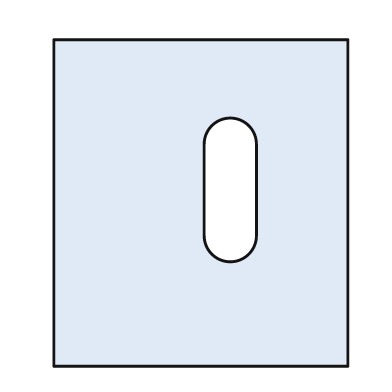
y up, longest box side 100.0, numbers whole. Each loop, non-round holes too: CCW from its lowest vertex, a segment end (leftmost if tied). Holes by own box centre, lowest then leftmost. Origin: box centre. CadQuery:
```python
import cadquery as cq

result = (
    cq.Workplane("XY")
    .moveTo(-45.0, -50.0)
    .lineTo(45.0, -50.0)
    .lineTo(45.0, 50.0)
    .lineTo(-45.0, 50.0)
    .close()
    .moveTo(1.0, -10.0)
    .threePointArc((9.0, -18.0), (17.0, -10.0))
    .lineTo(17.0, 18.0)
    .threePointArc((9.0, 26.0), (1.0, 18.0))
    .close()
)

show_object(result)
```